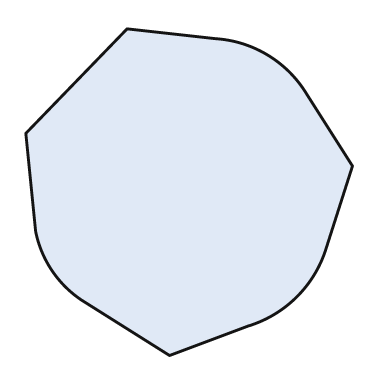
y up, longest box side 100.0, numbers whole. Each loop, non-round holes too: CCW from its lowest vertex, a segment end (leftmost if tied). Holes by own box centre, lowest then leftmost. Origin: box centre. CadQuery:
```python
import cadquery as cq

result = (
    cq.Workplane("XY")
    .moveTo(-6.0, -50.0)
    .lineTo(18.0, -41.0)
    .threePointArc((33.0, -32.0), (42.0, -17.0))
    .lineTo(50.0, 8.0)
    .lineTo(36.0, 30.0)
    .threePointArc((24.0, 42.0), (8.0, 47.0))
    .lineTo(-19.0, 50.0)
    .lineTo(-50.0, 18.0)
    .lineTo(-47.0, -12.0)
    .threePointArc((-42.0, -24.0), (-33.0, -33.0))
    .close()
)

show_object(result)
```